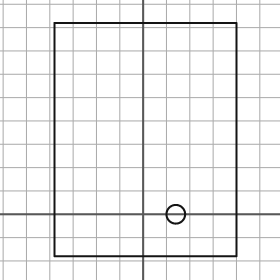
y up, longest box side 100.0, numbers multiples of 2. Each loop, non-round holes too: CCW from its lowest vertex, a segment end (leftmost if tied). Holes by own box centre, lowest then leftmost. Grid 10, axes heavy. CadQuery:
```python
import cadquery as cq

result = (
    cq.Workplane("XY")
    .moveTo(-38.0, -18.0)
    .lineTo(40.0, -18.0)
    .lineTo(40.0, 82.0)
    .lineTo(-38.0, 82.0)
    .close()
    .moveTo(14.0, 0.0)
    .circle(4.0)
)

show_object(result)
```